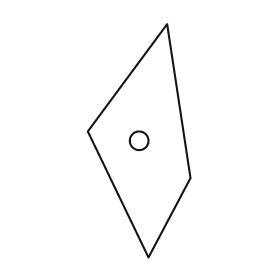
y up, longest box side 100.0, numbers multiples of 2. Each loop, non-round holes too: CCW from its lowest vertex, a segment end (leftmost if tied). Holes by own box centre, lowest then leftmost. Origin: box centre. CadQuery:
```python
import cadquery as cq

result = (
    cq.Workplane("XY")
    .moveTo(4.0, -50.0)
    .lineTo(22.0, -16.0)
    .lineTo(12.0, 50.0)
    .lineTo(-22.0, 4.0)
    .close()
    .moveTo(0.0, 0.0)
    .circle(4.0)
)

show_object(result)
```